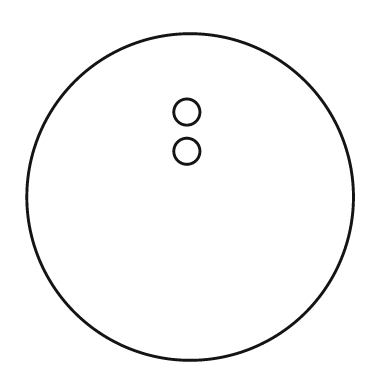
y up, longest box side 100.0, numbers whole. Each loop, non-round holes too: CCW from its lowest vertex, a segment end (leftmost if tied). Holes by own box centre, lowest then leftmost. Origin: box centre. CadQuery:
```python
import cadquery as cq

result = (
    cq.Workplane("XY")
    .moveTo(0.0, 0.0)
    .circle(50.0)
    .moveTo(-1.0, 14.0)
    .circle(4.0)
    .moveTo(-1.0, 26.0)
    .circle(4.0)
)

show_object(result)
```